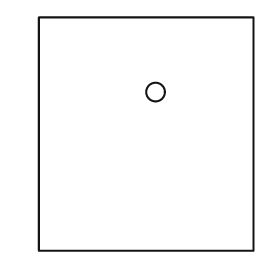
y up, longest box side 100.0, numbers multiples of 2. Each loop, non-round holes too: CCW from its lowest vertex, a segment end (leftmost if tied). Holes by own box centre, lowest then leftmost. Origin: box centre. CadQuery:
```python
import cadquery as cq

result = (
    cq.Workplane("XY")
    .moveTo(-46.0, -50.0)
    .lineTo(46.0, -50.0)
    .lineTo(46.0, 50.0)
    .lineTo(-46.0, 50.0)
    .close()
    .moveTo(4.0, 18.0)
    .circle(4.0)
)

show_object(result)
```